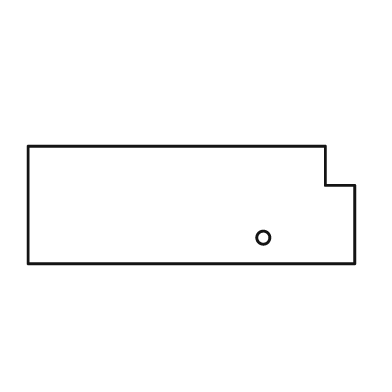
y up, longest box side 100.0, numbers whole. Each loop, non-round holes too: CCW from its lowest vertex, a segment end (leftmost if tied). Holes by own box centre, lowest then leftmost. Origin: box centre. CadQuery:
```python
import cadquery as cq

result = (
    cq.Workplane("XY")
    .moveTo(-50.0, -18.0)
    .lineTo(50.0, -18.0)
    .lineTo(50.0, 6.0)
    .lineTo(41.0, 6.0)
    .lineTo(41.0, 18.0)
    .lineTo(-50.0, 18.0)
    .close()
    .moveTo(22.0, -10.0)
    .circle(2.0)
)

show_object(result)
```